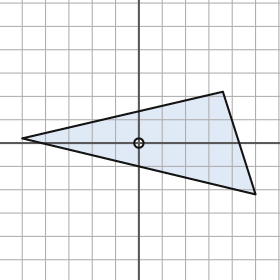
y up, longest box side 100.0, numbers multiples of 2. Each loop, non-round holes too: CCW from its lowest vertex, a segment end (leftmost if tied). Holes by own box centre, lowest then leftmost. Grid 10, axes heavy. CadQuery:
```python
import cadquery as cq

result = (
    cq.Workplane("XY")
    .moveTo(50.0, -22.0)
    .lineTo(36.0, 22.0)
    .lineTo(-50.0, 2.0)
    .close()
    .moveTo(0.0, 0.0)
    .circle(2.0)
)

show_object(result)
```